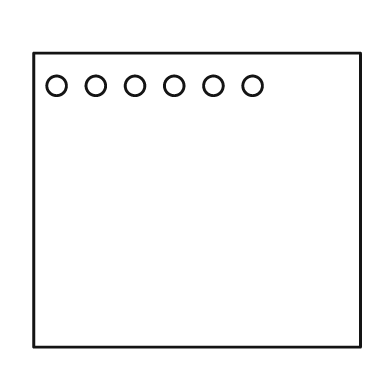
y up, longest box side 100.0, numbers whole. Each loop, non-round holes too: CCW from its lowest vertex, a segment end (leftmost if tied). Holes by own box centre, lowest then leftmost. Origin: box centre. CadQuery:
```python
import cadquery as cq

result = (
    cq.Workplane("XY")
    .moveTo(-50.0, -45.0)
    .lineTo(50.0, -45.0)
    .lineTo(50.0, 45.0)
    .lineTo(-50.0, 45.0)
    .close()
    .moveTo(-43.0, 35.0)
    .circle(3.0)
    .moveTo(-31.0, 35.0)
    .circle(3.0)
    .moveTo(-19.0, 35.0)
    .circle(3.0)
    .moveTo(-7.0, 35.0)
    .circle(3.0)
    .moveTo(5.0, 35.0)
    .circle(3.0)
    .moveTo(17.0, 35.0)
    .circle(3.0)
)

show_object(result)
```